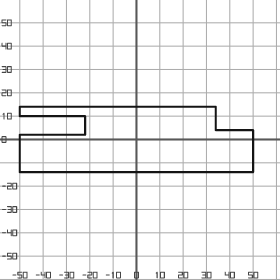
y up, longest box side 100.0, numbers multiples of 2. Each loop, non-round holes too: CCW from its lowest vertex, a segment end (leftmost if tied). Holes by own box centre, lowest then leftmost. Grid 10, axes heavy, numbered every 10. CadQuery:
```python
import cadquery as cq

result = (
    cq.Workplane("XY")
    .moveTo(-50.0, -14.0)
    .lineTo(50.0, -14.0)
    .lineTo(50.0, 4.0)
    .lineTo(34.0, 4.0)
    .lineTo(34.0, 14.0)
    .lineTo(-50.0, 14.0)
    .lineTo(-50.0, 10.0)
    .lineTo(-22.0, 10.0)
    .lineTo(-22.0, 2.0)
    .lineTo(-50.0, 2.0)
    .close()
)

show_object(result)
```